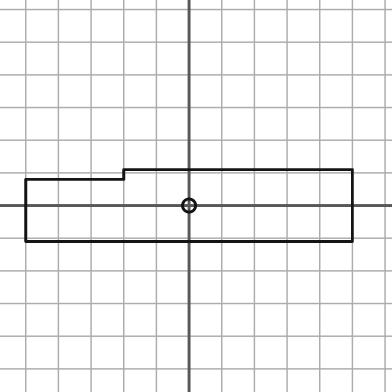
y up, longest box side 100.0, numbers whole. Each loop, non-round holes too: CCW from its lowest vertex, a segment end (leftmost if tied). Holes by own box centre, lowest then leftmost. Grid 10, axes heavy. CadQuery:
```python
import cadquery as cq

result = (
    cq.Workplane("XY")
    .moveTo(-50.0, -11.0)
    .lineTo(50.0, -11.0)
    .lineTo(50.0, 11.0)
    .lineTo(-20.0, 11.0)
    .lineTo(-20.0, 8.0)
    .lineTo(-50.0, 8.0)
    .close()
    .moveTo(0.0, 0.0)
    .circle(2.0)
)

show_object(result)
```